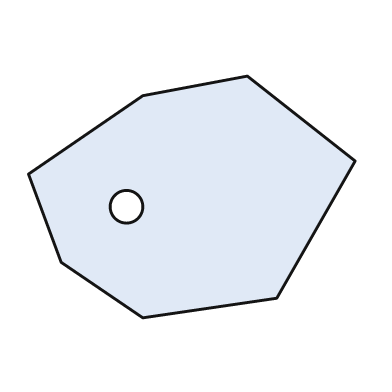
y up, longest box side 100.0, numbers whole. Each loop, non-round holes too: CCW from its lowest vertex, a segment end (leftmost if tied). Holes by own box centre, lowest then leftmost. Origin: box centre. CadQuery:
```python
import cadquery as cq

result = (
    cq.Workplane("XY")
    .moveTo(-15.0, -37.0)
    .lineTo(26.0, -31.0)
    .lineTo(50.0, 11.0)
    .lineTo(17.0, 37.0)
    .lineTo(-15.0, 31.0)
    .lineTo(-50.0, 7.0)
    .lineTo(-40.0, -20.0)
    .close()
    .moveTo(-20.0, -3.0)
    .circle(5.0)
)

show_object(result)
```